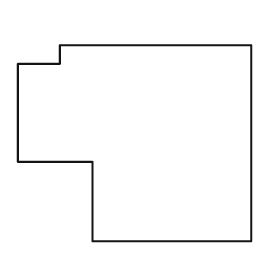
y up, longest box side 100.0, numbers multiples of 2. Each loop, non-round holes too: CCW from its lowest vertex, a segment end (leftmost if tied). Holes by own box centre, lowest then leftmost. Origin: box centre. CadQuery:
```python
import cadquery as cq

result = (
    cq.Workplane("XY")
    .moveTo(-18.0, -42.0)
    .lineTo(50.0, -42.0)
    .lineTo(50.0, 42.0)
    .lineTo(-32.0, 42.0)
    .lineTo(-32.0, 34.0)
    .lineTo(-50.0, 34.0)
    .lineTo(-50.0, -8.0)
    .lineTo(-18.0, -8.0)
    .close()
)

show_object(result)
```